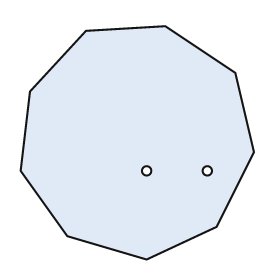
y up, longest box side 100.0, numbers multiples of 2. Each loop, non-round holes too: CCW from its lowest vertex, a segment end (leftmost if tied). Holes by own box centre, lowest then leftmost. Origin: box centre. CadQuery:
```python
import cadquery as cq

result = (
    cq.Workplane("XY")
    .moveTo(4.0, -50.0)
    .lineTo(34.0, -36.0)
    .lineTo(50.0, -4.0)
    .lineTo(42.0, 30.0)
    .lineTo(12.0, 50.0)
    .lineTo(-22.0, 48.0)
    .lineTo(-46.0, 22.0)
    .lineTo(-50.0, -12.0)
    .lineTo(-30.0, -40.0)
    .close()
    .moveTo(4.0, -12.0)
    .circle(2.0)
    .moveTo(30.0, -12.0)
    .circle(2.0)
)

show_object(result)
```